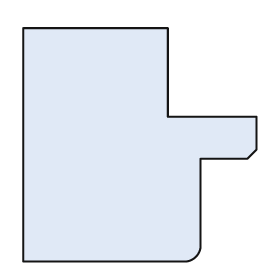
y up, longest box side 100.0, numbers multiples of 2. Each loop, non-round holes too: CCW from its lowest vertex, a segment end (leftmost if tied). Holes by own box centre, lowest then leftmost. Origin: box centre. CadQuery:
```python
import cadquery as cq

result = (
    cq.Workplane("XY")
    .moveTo(-50.0, -50.0)
    .lineTo(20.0, -50.0)
    .threePointArc((24.0, -48.0), (26.0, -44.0))
    .lineTo(26.0, -6.0)
    .lineTo(46.0, -6.0)
    .lineTo(50.0, -2.0)
    .lineTo(50.0, 12.0)
    .lineTo(12.0, 12.0)
    .lineTo(12.0, 50.0)
    .lineTo(-50.0, 50.0)
    .close()
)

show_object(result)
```